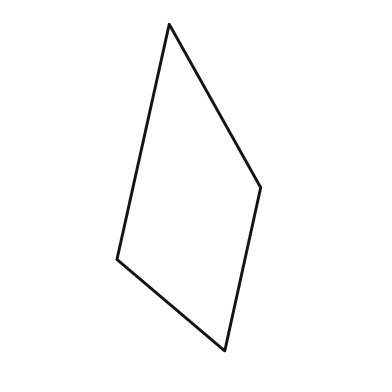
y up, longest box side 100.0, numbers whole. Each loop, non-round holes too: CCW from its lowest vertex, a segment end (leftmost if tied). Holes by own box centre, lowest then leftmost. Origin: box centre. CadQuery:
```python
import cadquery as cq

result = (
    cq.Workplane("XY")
    .moveTo(11.0, -50.0)
    .lineTo(22.0, 0.0)
    .lineTo(-6.0, 50.0)
    .lineTo(-22.0, -22.0)
    .close()
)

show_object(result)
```